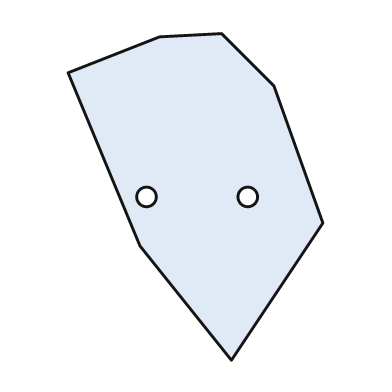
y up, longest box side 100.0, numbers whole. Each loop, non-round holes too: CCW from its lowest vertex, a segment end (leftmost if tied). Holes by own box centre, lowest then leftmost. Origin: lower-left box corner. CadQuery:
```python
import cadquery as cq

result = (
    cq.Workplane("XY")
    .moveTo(50.0, 0.0)
    .lineTo(78.0, 42.0)
    .lineTo(63.0, 84.0)
    .lineTo(47.0, 100.0)
    .lineTo(28.0, 99.0)
    .lineTo(0.0, 88.0)
    .lineTo(22.0, 35.0)
    .close()
    .moveTo(24.0, 50.0)
    .circle(3.0)
    .moveTo(55.0, 50.0)
    .circle(3.0)
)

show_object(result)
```